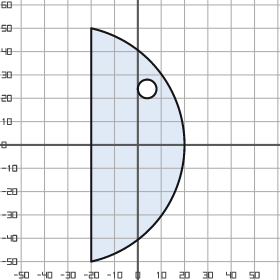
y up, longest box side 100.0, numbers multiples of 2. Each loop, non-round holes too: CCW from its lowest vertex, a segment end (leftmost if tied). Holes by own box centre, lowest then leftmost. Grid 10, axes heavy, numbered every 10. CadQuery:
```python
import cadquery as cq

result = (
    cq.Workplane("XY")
    .moveTo(-20.0, -50.0)
    .threePointArc((20.0, 0.0), (-20.0, 50.0))
    .close()
    .moveTo(4.0, 24.0)
    .circle(4.0)
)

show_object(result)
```